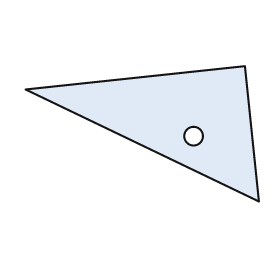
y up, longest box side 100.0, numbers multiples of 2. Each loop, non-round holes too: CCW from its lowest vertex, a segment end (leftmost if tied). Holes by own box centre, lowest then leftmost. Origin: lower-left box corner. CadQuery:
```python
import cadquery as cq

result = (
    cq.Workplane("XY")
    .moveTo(100.0, 0.0)
    .lineTo(94.0, 58.0)
    .lineTo(0.0, 48.0)
    .close()
    .moveTo(72.0, 28.0)
    .circle(4.0)
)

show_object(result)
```